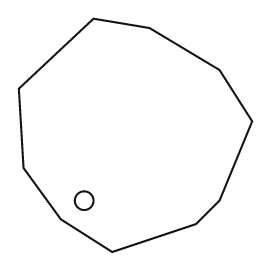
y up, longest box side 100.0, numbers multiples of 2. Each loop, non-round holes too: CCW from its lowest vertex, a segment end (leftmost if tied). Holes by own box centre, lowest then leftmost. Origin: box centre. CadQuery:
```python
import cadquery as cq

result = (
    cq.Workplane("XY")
    .moveTo(-10.0, -50.0)
    .lineTo(26.0, -38.0)
    .lineTo(36.0, -28.0)
    .lineTo(50.0, 6.0)
    .lineTo(36.0, 28.0)
    .lineTo(6.0, 46.0)
    .lineTo(-18.0, 50.0)
    .lineTo(-50.0, 20.0)
    .lineTo(-48.0, -14.0)
    .lineTo(-32.0, -36.0)
    .close()
    .moveTo(-22.0, -28.0)
    .circle(4.0)
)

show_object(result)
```